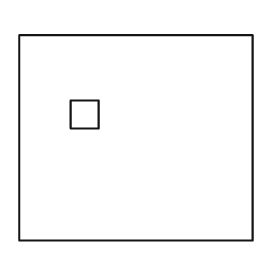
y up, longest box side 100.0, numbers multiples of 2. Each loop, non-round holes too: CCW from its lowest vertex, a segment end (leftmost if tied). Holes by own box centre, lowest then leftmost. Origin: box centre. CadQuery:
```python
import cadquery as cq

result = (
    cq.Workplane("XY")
    .moveTo(-50.0, -44.0)
    .lineTo(50.0, -44.0)
    .lineTo(50.0, 44.0)
    .lineTo(-50.0, 44.0)
    .close()
    .moveTo(-28.0, 4.0)
    .lineTo(-16.0, 4.0)
    .lineTo(-16.0, 16.0)
    .lineTo(-28.0, 16.0)
    .close()
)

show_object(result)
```